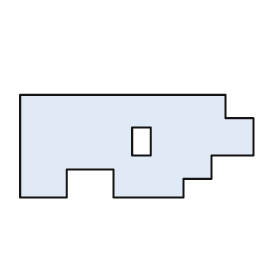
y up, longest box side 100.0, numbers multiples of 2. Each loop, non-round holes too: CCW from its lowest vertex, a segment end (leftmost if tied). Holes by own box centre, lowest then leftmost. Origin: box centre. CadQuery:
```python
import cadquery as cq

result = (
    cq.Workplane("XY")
    .moveTo(-50.0, -22.0)
    .lineTo(-30.0, -22.0)
    .lineTo(-30.0, -10.0)
    .lineTo(-10.0, -10.0)
    .lineTo(-10.0, -22.0)
    .lineTo(20.0, -22.0)
    .lineTo(20.0, -14.0)
    .lineTo(32.0, -14.0)
    .lineTo(32.0, -4.0)
    .lineTo(50.0, -4.0)
    .lineTo(50.0, 12.0)
    .lineTo(38.0, 12.0)
    .lineTo(38.0, 22.0)
    .lineTo(-50.0, 22.0)
    .close()
    .moveTo(-2.0, -4.0)
    .lineTo(6.0, -4.0)
    .lineTo(6.0, 8.0)
    .lineTo(-2.0, 8.0)
    .close()
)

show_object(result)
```